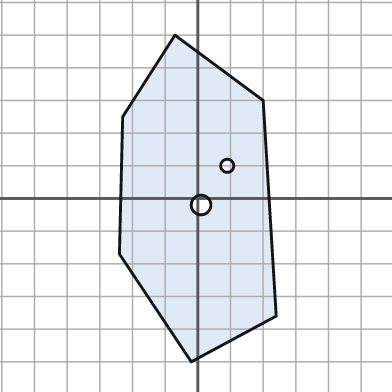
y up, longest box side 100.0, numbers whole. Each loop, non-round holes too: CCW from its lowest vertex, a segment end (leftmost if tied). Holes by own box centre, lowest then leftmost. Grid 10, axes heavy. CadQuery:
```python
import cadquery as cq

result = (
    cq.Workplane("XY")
    .moveTo(-2.0, -50.0)
    .lineTo(24.0, -36.0)
    .lineTo(20.0, 30.0)
    .lineTo(-7.0, 50.0)
    .lineTo(-23.0, 25.0)
    .lineTo(-24.0, -17.0)
    .close()
    .moveTo(1.0, -2.0)
    .circle(3.0)
    .moveTo(9.0, 10.0)
    .circle(2.0)
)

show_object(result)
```